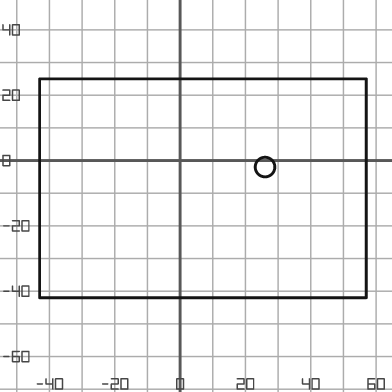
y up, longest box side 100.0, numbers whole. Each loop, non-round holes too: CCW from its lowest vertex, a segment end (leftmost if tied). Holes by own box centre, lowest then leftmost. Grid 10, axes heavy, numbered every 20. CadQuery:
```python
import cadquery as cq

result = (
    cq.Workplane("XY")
    .moveTo(-43.0, -42.0)
    .lineTo(57.0, -42.0)
    .lineTo(57.0, 25.0)
    .lineTo(-43.0, 25.0)
    .close()
    .moveTo(26.0, -2.0)
    .circle(3.0)
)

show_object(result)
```